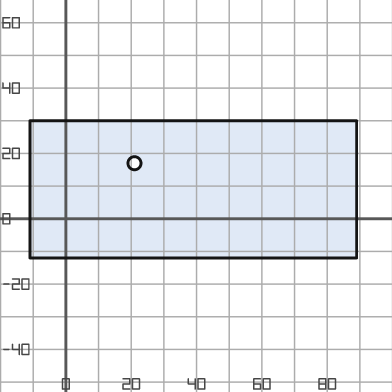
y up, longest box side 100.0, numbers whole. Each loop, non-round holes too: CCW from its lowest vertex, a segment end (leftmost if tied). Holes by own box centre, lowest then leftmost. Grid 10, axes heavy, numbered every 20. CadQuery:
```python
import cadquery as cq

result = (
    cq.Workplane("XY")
    .moveTo(-11.0, -12.0)
    .lineTo(89.0, -12.0)
    .lineTo(89.0, 30.0)
    .lineTo(-11.0, 30.0)
    .close()
    .moveTo(21.0, 17.0)
    .circle(2.0)
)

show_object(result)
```